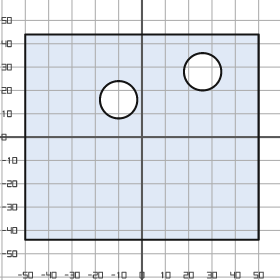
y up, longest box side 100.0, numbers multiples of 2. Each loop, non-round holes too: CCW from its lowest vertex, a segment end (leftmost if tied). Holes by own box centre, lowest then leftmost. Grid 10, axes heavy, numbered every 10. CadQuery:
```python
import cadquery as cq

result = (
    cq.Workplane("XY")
    .moveTo(-50.0, -44.0)
    .lineTo(50.0, -44.0)
    .lineTo(50.0, 44.0)
    .lineTo(-50.0, 44.0)
    .close()
    .moveTo(-10.0, 16.0)
    .circle(8.0)
    .moveTo(26.0, 28.0)
    .circle(8.0)
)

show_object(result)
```